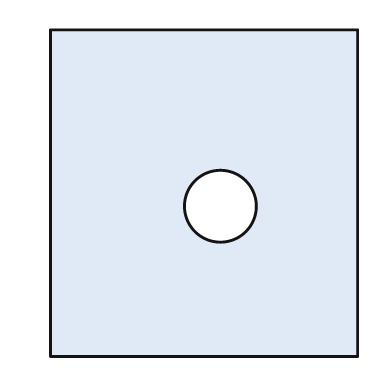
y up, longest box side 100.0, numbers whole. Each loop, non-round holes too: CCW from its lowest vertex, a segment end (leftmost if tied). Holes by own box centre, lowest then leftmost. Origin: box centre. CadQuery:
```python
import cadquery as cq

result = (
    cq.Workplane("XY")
    .moveTo(-47.0, -50.0)
    .lineTo(47.0, -50.0)
    .lineTo(47.0, 50.0)
    .lineTo(-47.0, 50.0)
    .close()
    .moveTo(5.0, -4.0)
    .circle(11.0)
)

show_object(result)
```